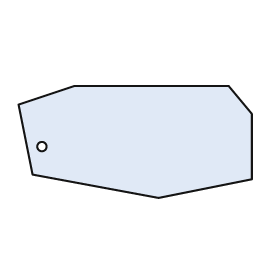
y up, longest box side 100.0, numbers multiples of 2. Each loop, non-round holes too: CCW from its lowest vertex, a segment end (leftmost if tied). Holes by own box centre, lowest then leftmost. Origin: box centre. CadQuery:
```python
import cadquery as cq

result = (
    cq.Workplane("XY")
    .moveTo(10.0, -24.0)
    .lineTo(50.0, -16.0)
    .lineTo(50.0, 12.0)
    .lineTo(40.0, 24.0)
    .lineTo(-26.0, 24.0)
    .lineTo(-50.0, 16.0)
    .lineTo(-44.0, -14.0)
    .close()
    .moveTo(-40.0, -2.0)
    .circle(2.0)
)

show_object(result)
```